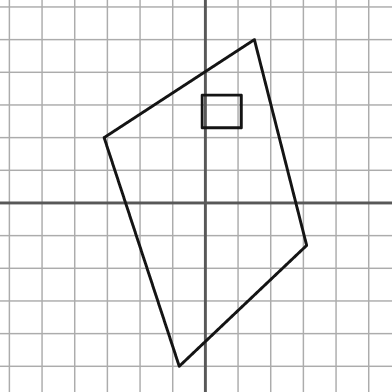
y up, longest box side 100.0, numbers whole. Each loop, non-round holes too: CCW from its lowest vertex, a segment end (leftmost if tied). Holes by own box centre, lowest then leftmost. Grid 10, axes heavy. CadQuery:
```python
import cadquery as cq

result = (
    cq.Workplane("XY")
    .moveTo(-8.0, -50.0)
    .lineTo(31.0, -13.0)
    .lineTo(15.0, 50.0)
    .lineTo(-31.0, 20.0)
    .close()
    .moveTo(-1.0, 23.0)
    .lineTo(11.0, 23.0)
    .lineTo(11.0, 33.0)
    .lineTo(-1.0, 33.0)
    .close()
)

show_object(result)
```